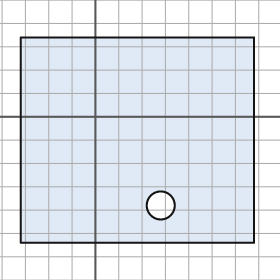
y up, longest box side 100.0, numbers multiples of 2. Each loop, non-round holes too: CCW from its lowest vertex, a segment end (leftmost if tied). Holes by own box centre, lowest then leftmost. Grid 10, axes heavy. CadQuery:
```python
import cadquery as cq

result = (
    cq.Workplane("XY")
    .moveTo(-32.0, -54.0)
    .lineTo(68.0, -54.0)
    .lineTo(68.0, 34.0)
    .lineTo(-32.0, 34.0)
    .close()
    .moveTo(28.0, -38.0)
    .circle(6.0)
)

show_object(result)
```